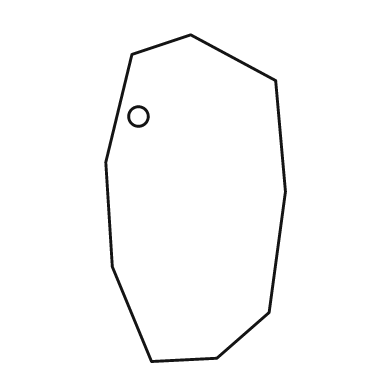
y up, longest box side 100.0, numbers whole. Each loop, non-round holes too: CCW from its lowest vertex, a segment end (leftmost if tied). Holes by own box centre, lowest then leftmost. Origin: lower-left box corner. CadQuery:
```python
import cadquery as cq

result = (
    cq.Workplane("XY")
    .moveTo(14.0, 0.0)
    .lineTo(34.0, 1.0)
    .lineTo(50.0, 15.0)
    .lineTo(55.0, 52.0)
    .lineTo(52.0, 86.0)
    .lineTo(26.0, 100.0)
    .lineTo(8.0, 94.0)
    .lineTo(0.0, 61.0)
    .lineTo(2.0, 29.0)
    .close()
    .moveTo(10.0, 75.0)
    .circle(3.0)
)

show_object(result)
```